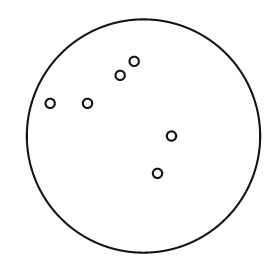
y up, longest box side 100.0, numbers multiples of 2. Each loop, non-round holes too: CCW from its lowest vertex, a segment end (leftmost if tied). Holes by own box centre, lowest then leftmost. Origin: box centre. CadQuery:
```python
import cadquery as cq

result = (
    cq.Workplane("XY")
    .moveTo(0.0, 0.0)
    .circle(50.0)
    .moveTo(6.0, -16.0)
    .circle(2.0)
    .moveTo(12.0, 0.0)
    .circle(2.0)
    .moveTo(-40.0, 14.0)
    .circle(2.0)
    .moveTo(-24.0, 14.0)
    .circle(2.0)
    .moveTo(-10.0, 26.0)
    .circle(2.0)
    .moveTo(-4.0, 32.0)
    .circle(2.0)
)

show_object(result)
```